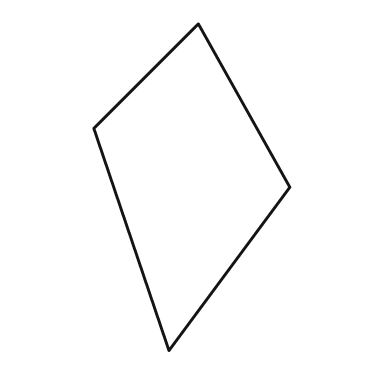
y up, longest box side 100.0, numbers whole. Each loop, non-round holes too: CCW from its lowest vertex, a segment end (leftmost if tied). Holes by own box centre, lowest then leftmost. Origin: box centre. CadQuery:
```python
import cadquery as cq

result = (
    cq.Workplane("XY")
    .moveTo(-7.0, -50.0)
    .lineTo(30.0, 0.0)
    .lineTo(2.0, 50.0)
    .lineTo(-30.0, 18.0)
    .close()
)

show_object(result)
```